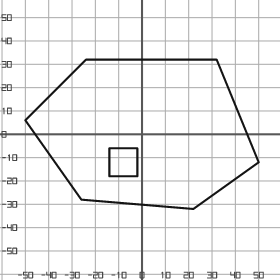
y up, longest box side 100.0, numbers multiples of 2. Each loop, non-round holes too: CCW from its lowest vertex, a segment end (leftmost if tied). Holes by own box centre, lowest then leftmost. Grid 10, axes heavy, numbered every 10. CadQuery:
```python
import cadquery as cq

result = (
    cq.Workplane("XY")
    .moveTo(22.0, -32.0)
    .lineTo(50.0, -12.0)
    .lineTo(32.0, 32.0)
    .lineTo(-24.0, 32.0)
    .lineTo(-50.0, 6.0)
    .lineTo(-26.0, -28.0)
    .close()
    .moveTo(-14.0, -18.0)
    .lineTo(-2.0, -18.0)
    .lineTo(-2.0, -6.0)
    .lineTo(-14.0, -6.0)
    .close()
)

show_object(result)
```